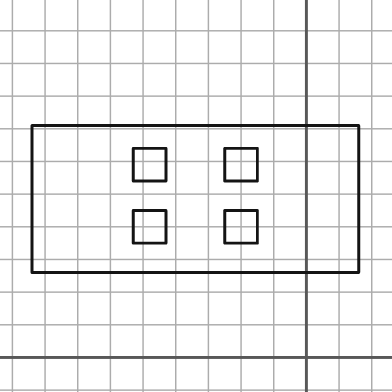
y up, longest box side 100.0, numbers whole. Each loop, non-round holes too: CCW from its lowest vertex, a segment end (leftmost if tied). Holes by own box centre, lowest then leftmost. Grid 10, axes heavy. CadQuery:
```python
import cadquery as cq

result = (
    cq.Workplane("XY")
    .moveTo(-84.0, 26.0)
    .lineTo(16.0, 26.0)
    .lineTo(16.0, 71.0)
    .lineTo(-84.0, 71.0)
    .close()
    .moveTo(-53.0, 35.0)
    .lineTo(-43.0, 35.0)
    .lineTo(-43.0, 45.0)
    .lineTo(-53.0, 45.0)
    .close()
    .moveTo(-25.0, 35.0)
    .lineTo(-15.0, 35.0)
    .lineTo(-15.0, 45.0)
    .lineTo(-25.0, 45.0)
    .close()
    .moveTo(-53.0, 54.0)
    .lineTo(-43.0, 54.0)
    .lineTo(-43.0, 64.0)
    .lineTo(-53.0, 64.0)
    .close()
    .moveTo(-25.0, 54.0)
    .lineTo(-15.0, 54.0)
    .lineTo(-15.0, 64.0)
    .lineTo(-25.0, 64.0)
    .close()
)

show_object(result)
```